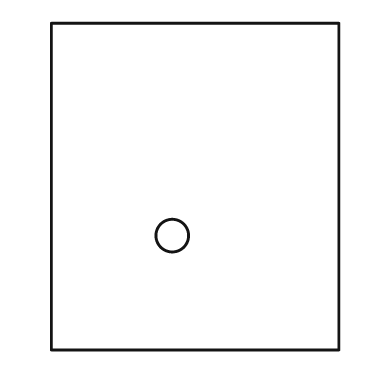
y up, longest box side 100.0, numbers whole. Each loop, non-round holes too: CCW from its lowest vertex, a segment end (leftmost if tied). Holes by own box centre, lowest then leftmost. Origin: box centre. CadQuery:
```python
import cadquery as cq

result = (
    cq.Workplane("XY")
    .moveTo(-44.0, -50.0)
    .lineTo(44.0, -50.0)
    .lineTo(44.0, 50.0)
    .lineTo(-44.0, 50.0)
    .close()
    .moveTo(-7.0, -15.0)
    .circle(5.0)
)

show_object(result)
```